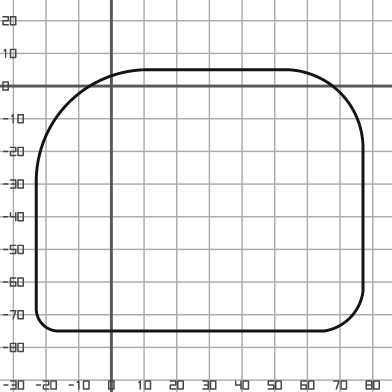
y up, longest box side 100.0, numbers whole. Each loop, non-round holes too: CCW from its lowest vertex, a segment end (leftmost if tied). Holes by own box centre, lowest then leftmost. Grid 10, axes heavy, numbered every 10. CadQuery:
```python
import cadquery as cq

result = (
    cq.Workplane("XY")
    .moveTo(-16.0, -75.0)
    .lineTo(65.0, -75.0)
    .threePointArc((73.0, -71.0), (77.0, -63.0))
    .lineTo(77.0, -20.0)
    .threePointArc((70.0, -2.0), (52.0, 5.0))
    .lineTo(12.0, 5.0)
    .threePointArc((-13.0, -5.0), (-23.0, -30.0))
    .lineTo(-23.0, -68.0)
    .threePointArc((-21.0, -73.0), (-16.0, -75.0))
    .close()
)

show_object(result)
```